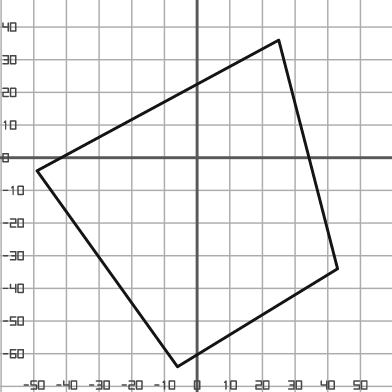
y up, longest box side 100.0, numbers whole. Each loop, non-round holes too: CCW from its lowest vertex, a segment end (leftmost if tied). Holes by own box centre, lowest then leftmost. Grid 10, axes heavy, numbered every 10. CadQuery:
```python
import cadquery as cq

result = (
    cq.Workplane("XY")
    .moveTo(-6.0, -64.0)
    .lineTo(43.0, -34.0)
    .lineTo(25.0, 36.0)
    .lineTo(-49.0, -4.0)
    .close()
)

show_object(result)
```